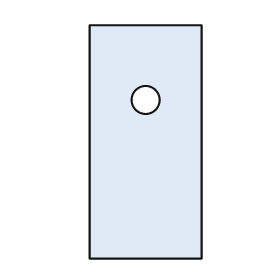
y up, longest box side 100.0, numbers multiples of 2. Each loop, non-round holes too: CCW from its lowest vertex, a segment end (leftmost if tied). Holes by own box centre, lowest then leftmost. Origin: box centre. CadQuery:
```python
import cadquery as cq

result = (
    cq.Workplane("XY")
    .moveTo(-24.0, -50.0)
    .lineTo(24.0, -50.0)
    .lineTo(24.0, 50.0)
    .lineTo(-24.0, 50.0)
    .close()
    .moveTo(0.0, 18.0)
    .circle(6.0)
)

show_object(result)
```